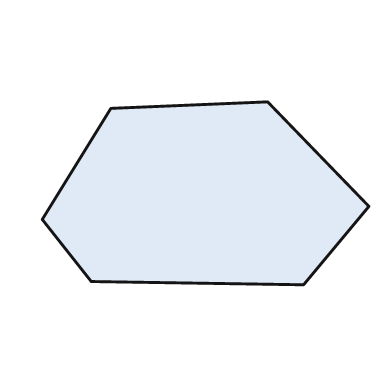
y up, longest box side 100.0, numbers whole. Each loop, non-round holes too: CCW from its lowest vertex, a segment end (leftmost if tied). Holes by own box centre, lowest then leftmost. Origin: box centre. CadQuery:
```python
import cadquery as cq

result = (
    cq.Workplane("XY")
    .moveTo(30.0, -28.0)
    .lineTo(50.0, -4.0)
    .lineTo(19.0, 28.0)
    .lineTo(-29.0, 26.0)
    .lineTo(-50.0, -8.0)
    .lineTo(-35.0, -27.0)
    .close()
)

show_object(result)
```